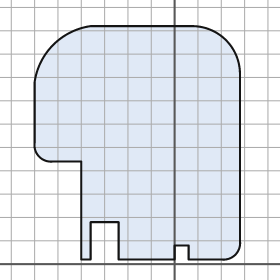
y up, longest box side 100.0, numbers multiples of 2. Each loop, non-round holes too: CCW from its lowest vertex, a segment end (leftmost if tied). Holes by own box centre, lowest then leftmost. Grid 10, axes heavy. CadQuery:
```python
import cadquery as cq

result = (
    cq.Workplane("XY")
    .moveTo(-40.0, 2.0)
    .lineTo(-36.0, 2.0)
    .lineTo(-36.0, 18.0)
    .lineTo(-24.0, 18.0)
    .lineTo(-24.0, 2.0)
    .lineTo(0.0, 2.0)
    .lineTo(0.0, 8.0)
    .lineTo(6.0, 8.0)
    .lineTo(6.0, 2.0)
    .lineTo(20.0, 2.0)
    .threePointArc((26.0, 4.0), (28.0, 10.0))
    .lineTo(28.0, 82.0)
    .threePointArc((22.0, 96.0), (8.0, 102.0))
    .lineTo(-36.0, 102.0)
    .threePointArc((-52.0, 94.0), (-60.0, 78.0))
    .lineTo(-60.0, 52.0)
    .threePointArc((-58.0, 46.0), (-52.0, 44.0))
    .lineTo(-40.0, 44.0)
    .close()
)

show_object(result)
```